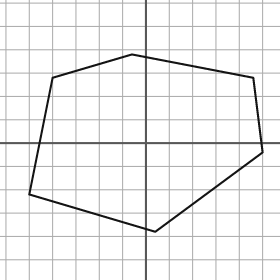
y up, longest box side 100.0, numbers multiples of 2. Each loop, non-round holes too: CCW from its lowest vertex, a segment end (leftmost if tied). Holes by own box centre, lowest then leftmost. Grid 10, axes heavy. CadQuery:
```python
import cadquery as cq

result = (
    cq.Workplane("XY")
    .moveTo(4.0, -38.0)
    .lineTo(50.0, -4.0)
    .lineTo(46.0, 28.0)
    .lineTo(-6.0, 38.0)
    .lineTo(-40.0, 28.0)
    .lineTo(-50.0, -22.0)
    .close()
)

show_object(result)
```